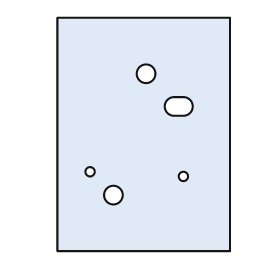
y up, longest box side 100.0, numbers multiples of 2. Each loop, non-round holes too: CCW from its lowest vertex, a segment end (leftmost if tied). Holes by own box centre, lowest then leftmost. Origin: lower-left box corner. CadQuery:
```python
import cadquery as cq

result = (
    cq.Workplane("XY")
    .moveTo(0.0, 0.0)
    .lineTo(74.0, 0.0)
    .lineTo(74.0, 100.0)
    .lineTo(0.0, 100.0)
    .close()
    .moveTo(24.0, 24.0)
    .circle(4.0)
    .moveTo(54.0, 32.0)
    .circle(2.0)
    .moveTo(14.0, 34.0)
    .circle(2.0)
    .moveTo(50.0, 58.0)
    .lineTo(54.0, 58.0)
    .threePointArc((58.0, 62.0), (54.0, 66.0))
    .lineTo(50.0, 66.0)
    .threePointArc((46.0, 62.0), (50.0, 58.0))
    .close()
    .moveTo(38.0, 76.0)
    .circle(4.0)
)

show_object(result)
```